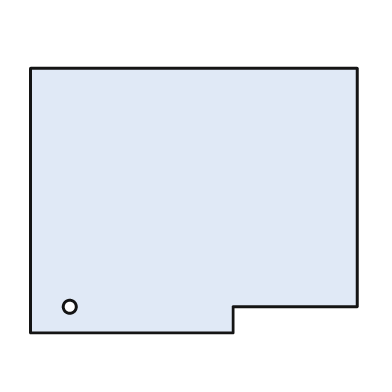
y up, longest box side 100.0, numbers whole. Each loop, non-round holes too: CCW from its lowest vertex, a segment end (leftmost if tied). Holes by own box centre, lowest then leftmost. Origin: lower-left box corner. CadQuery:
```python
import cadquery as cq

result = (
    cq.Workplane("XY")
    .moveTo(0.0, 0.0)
    .lineTo(62.0, 0.0)
    .lineTo(62.0, 8.0)
    .lineTo(100.0, 8.0)
    .lineTo(100.0, 81.0)
    .lineTo(0.0, 81.0)
    .close()
    .moveTo(12.0, 8.0)
    .circle(2.0)
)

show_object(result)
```